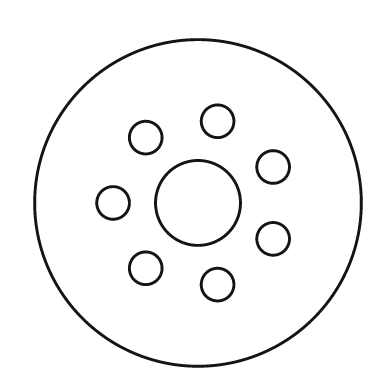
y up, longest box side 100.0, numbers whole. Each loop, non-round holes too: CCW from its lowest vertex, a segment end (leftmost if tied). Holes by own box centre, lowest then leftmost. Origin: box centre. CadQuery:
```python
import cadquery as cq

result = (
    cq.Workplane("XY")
    .moveTo(0.0, 0.0)
    .circle(50.0)
    .moveTo(6.0, -25.0)
    .circle(5.0)
    .moveTo(-16.0, -20.0)
    .circle(5.0)
    .moveTo(23.0, -11.0)
    .circle(5.0)
    .moveTo(-26.0, 0.0)
    .circle(5.0)
    .moveTo(0.0, 0.0)
    .circle(13.0)
    .moveTo(23.0, 11.0)
    .circle(5.0)
    .moveTo(-16.0, 20.0)
    .circle(5.0)
    .moveTo(6.0, 25.0)
    .circle(5.0)
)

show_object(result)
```